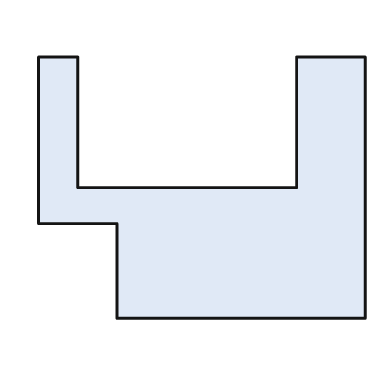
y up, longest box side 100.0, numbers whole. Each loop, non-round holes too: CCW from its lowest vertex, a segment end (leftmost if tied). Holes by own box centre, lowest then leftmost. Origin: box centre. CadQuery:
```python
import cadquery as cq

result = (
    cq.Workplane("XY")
    .moveTo(-26.0, -40.0)
    .lineTo(50.0, -40.0)
    .lineTo(50.0, 40.0)
    .lineTo(29.0, 40.0)
    .lineTo(29.0, 0.0)
    .lineTo(-38.0, 0.0)
    .lineTo(-38.0, 40.0)
    .lineTo(-50.0, 40.0)
    .lineTo(-50.0, -11.0)
    .lineTo(-26.0, -11.0)
    .close()
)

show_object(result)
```